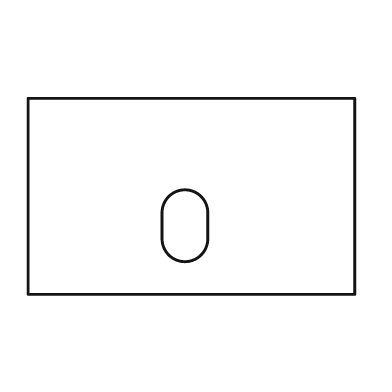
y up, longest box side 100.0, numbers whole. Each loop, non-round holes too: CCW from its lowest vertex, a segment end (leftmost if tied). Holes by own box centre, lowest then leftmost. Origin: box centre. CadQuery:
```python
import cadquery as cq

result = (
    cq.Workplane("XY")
    .moveTo(-50.0, -30.0)
    .lineTo(50.0, -30.0)
    .lineTo(50.0, 30.0)
    .lineTo(-50.0, 30.0)
    .close()
    .moveTo(-9.0, -13.0)
    .threePointArc((-2.0, -20.0), (5.0, -13.0))
    .lineTo(5.0, -5.0)
    .threePointArc((-2.0, 2.0), (-9.0, -5.0))
    .close()
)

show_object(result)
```